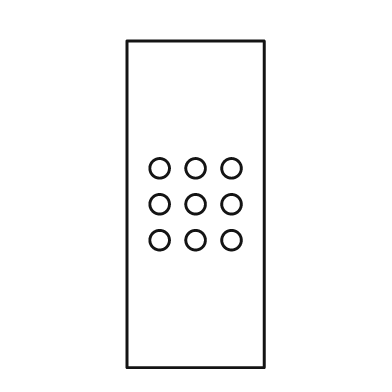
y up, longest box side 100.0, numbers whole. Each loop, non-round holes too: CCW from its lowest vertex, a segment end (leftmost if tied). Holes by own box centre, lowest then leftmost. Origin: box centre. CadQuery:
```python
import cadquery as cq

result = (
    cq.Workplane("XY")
    .moveTo(-21.0, -50.0)
    .lineTo(21.0, -50.0)
    .lineTo(21.0, 50.0)
    .lineTo(-21.0, 50.0)
    .close()
    .moveTo(-11.0, -11.0)
    .circle(3.0)
    .moveTo(0.0, -11.0)
    .circle(3.0)
    .moveTo(11.0, -11.0)
    .circle(3.0)
    .moveTo(-11.0, 0.0)
    .circle(3.0)
    .moveTo(0.0, 0.0)
    .circle(3.0)
    .moveTo(11.0, 0.0)
    .circle(3.0)
    .moveTo(-11.0, 11.0)
    .circle(3.0)
    .moveTo(0.0, 11.0)
    .circle(3.0)
    .moveTo(11.0, 11.0)
    .circle(3.0)
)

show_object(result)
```